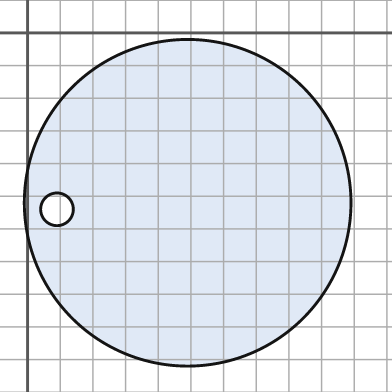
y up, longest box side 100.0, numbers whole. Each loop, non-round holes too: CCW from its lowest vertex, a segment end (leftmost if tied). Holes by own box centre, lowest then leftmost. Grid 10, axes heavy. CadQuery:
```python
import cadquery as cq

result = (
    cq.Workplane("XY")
    .moveTo(49.0, -52.0)
    .circle(50.0)
    .moveTo(9.0, -54.0)
    .circle(5.0)
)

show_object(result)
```